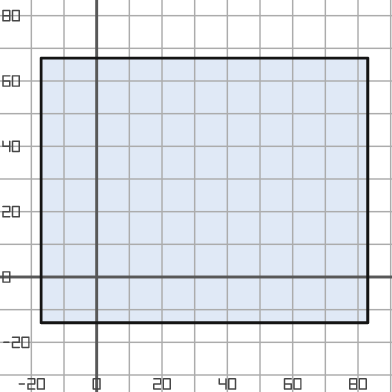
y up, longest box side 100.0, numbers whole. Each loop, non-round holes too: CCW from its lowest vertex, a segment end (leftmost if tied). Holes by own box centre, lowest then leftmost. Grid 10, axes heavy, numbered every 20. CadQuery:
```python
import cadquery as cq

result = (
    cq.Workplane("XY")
    .moveTo(-17.0, -14.0)
    .lineTo(83.0, -14.0)
    .lineTo(83.0, 67.0)
    .lineTo(-17.0, 67.0)
    .close()
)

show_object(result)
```